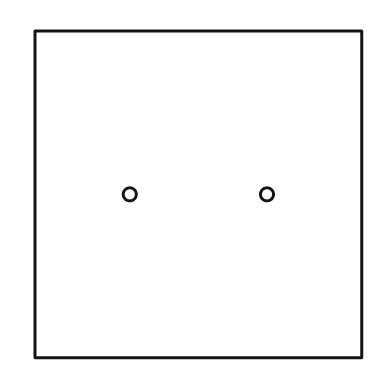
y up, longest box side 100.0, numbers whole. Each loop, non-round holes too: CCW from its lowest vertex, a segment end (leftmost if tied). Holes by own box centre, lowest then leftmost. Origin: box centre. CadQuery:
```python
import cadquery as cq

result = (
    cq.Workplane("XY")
    .moveTo(-50.0, -50.0)
    .lineTo(50.0, -50.0)
    .lineTo(50.0, 50.0)
    .lineTo(-50.0, 50.0)
    .close()
    .moveTo(-21.0, 0.0)
    .circle(2.0)
    .moveTo(21.0, 0.0)
    .circle(2.0)
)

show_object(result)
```